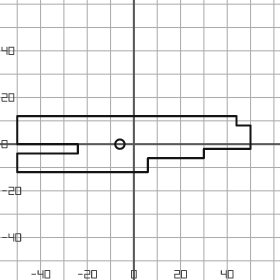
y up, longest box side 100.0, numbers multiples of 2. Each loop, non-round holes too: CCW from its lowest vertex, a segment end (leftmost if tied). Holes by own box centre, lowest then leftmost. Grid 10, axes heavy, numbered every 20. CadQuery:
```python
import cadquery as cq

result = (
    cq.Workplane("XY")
    .moveTo(-50.0, -12.0)
    .lineTo(6.0, -12.0)
    .lineTo(6.0, -6.0)
    .lineTo(30.0, -6.0)
    .lineTo(30.0, -2.0)
    .lineTo(50.0, -2.0)
    .lineTo(50.0, 8.0)
    .lineTo(44.0, 8.0)
    .lineTo(44.0, 12.0)
    .lineTo(-50.0, 12.0)
    .lineTo(-50.0, 0.0)
    .lineTo(-24.0, 0.0)
    .lineTo(-24.0, -4.0)
    .lineTo(-50.0, -4.0)
    .close()
    .moveTo(-6.0, 0.0)
    .circle(2.0)
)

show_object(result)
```